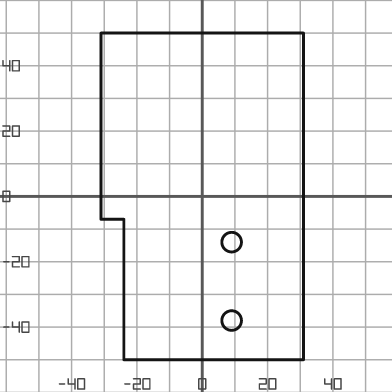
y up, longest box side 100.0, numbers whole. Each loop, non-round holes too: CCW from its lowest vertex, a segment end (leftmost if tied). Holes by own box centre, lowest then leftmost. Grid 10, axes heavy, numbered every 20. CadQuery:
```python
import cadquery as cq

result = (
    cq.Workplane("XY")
    .moveTo(-24.0, -50.0)
    .lineTo(31.0, -50.0)
    .lineTo(31.0, 50.0)
    .lineTo(-31.0, 50.0)
    .lineTo(-31.0, -7.0)
    .lineTo(-24.0, -7.0)
    .close()
    .moveTo(9.0, -38.0)
    .circle(3.0)
    .moveTo(9.0, -14.0)
    .circle(3.0)
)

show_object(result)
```